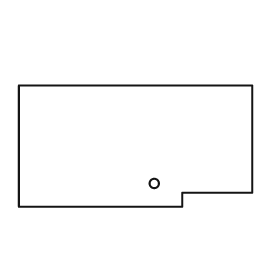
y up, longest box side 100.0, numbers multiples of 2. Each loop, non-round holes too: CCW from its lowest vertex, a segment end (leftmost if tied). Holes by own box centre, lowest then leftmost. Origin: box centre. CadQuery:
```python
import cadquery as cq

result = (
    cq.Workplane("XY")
    .moveTo(-50.0, -26.0)
    .lineTo(20.0, -26.0)
    .lineTo(20.0, -20.0)
    .lineTo(50.0, -20.0)
    .lineTo(50.0, 26.0)
    .lineTo(-50.0, 26.0)
    .close()
    .moveTo(8.0, -16.0)
    .circle(2.0)
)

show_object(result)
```